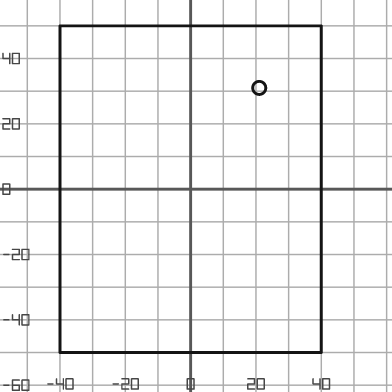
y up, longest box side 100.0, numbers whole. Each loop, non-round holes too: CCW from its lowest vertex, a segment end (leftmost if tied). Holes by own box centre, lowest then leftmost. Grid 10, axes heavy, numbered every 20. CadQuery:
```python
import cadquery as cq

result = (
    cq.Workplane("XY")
    .moveTo(-40.0, -50.0)
    .lineTo(40.0, -50.0)
    .lineTo(40.0, 50.0)
    .lineTo(-40.0, 50.0)
    .close()
    .moveTo(21.0, 31.0)
    .circle(2.0)
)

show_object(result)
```